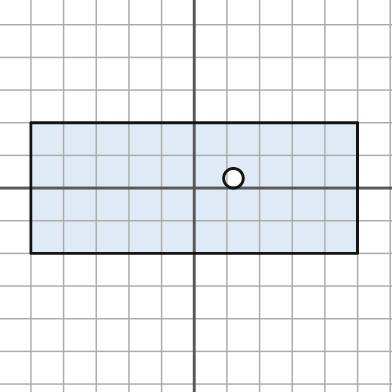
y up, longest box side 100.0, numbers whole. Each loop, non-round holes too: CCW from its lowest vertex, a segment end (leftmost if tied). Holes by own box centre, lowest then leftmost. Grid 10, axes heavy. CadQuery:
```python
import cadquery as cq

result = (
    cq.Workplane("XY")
    .moveTo(-50.0, -20.0)
    .lineTo(50.0, -20.0)
    .lineTo(50.0, 20.0)
    .lineTo(-50.0, 20.0)
    .close()
    .moveTo(12.0, 3.0)
    .circle(3.0)
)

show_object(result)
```